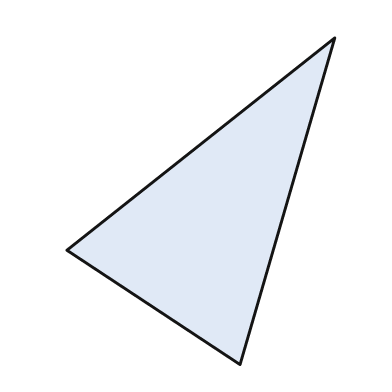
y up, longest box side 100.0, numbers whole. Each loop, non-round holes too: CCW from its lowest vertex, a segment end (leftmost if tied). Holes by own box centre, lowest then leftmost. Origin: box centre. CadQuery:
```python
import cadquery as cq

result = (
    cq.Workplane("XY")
    .moveTo(12.0, -50.0)
    .lineTo(41.0, 50.0)
    .lineTo(-41.0, -15.0)
    .close()
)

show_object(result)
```